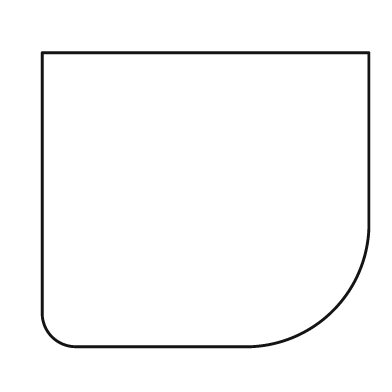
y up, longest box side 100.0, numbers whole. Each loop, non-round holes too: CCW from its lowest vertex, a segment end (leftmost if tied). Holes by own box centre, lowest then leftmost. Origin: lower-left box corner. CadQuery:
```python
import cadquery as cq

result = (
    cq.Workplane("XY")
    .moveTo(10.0, 0.0)
    .lineTo(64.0, 0.0)
    .threePointArc((89.0, 11.0), (100.0, 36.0))
    .lineTo(100.0, 90.0)
    .lineTo(0.0, 90.0)
    .lineTo(0.0, 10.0)
    .threePointArc((3.0, 3.0), (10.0, 0.0))
    .close()
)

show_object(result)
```